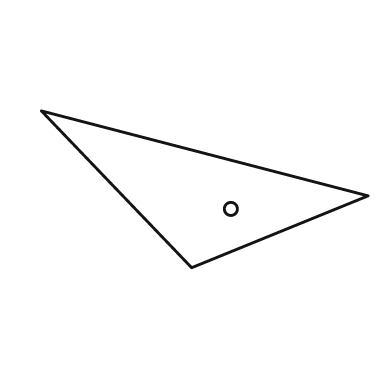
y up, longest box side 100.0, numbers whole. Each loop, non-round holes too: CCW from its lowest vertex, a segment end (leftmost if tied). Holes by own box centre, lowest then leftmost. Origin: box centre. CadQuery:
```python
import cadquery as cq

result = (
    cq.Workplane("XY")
    .moveTo(-4.0, -24.0)
    .lineTo(50.0, -2.0)
    .lineTo(-50.0, 24.0)
    .close()
    .moveTo(8.0, -6.0)
    .circle(2.0)
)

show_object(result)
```